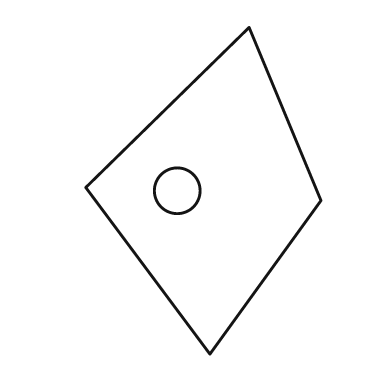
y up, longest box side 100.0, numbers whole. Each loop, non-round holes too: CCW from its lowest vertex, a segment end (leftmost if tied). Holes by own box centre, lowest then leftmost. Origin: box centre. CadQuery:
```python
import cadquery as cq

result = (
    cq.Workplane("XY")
    .moveTo(2.0, -50.0)
    .lineTo(36.0, -3.0)
    .lineTo(14.0, 50.0)
    .lineTo(-36.0, 1.0)
    .close()
    .moveTo(-8.0, 0.0)
    .circle(7.0)
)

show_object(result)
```